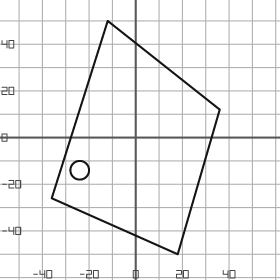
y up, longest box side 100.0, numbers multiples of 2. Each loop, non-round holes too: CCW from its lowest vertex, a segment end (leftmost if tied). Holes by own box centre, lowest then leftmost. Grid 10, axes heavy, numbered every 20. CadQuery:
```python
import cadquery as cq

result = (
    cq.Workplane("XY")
    .moveTo(18.0, -50.0)
    .lineTo(36.0, 12.0)
    .lineTo(-12.0, 50.0)
    .lineTo(-36.0, -26.0)
    .close()
    .moveTo(-24.0, -14.0)
    .circle(4.0)
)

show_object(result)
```